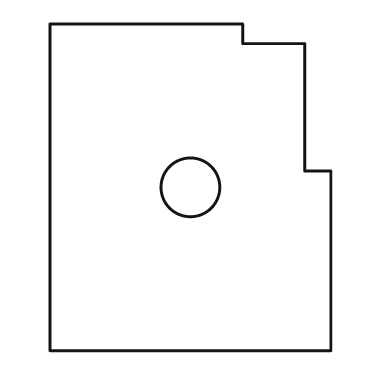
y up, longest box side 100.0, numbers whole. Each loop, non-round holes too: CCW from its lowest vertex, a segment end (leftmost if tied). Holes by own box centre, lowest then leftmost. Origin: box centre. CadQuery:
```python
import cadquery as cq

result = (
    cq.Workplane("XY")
    .moveTo(-43.0, -50.0)
    .lineTo(43.0, -50.0)
    .lineTo(43.0, 5.0)
    .lineTo(35.0, 5.0)
    .lineTo(35.0, 44.0)
    .lineTo(16.0, 44.0)
    .lineTo(16.0, 50.0)
    .lineTo(-43.0, 50.0)
    .close()
    .moveTo(0.0, 0.0)
    .circle(9.0)
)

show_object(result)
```